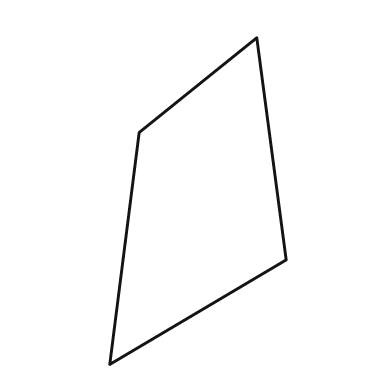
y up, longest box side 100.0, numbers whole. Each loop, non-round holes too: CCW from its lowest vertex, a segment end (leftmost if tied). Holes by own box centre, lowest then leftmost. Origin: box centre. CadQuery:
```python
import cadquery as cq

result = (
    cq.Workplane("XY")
    .moveTo(-27.0, -50.0)
    .lineTo(27.0, -18.0)
    .lineTo(18.0, 50.0)
    .lineTo(-18.0, 21.0)
    .close()
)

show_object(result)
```